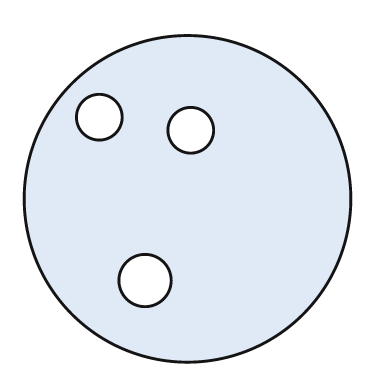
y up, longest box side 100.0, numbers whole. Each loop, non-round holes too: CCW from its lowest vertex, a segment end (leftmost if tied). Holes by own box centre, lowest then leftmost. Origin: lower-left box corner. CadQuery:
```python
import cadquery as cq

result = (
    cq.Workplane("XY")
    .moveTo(50.0, 50.0)
    .circle(50.0)
    .moveTo(37.0, 25.0)
    .circle(8.0)
    .moveTo(51.0, 71.0)
    .circle(7.0)
    .moveTo(23.0, 75.0)
    .circle(7.0)
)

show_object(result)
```